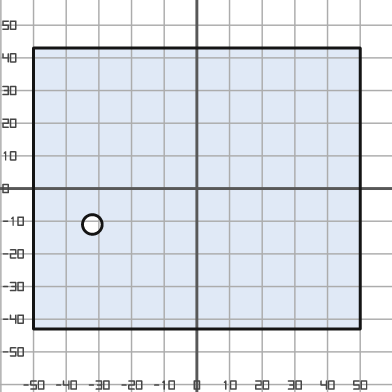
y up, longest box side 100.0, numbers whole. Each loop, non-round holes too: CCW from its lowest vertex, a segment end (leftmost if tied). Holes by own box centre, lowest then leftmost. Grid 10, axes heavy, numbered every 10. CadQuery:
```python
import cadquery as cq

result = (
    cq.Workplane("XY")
    .moveTo(-50.0, -43.0)
    .lineTo(50.0, -43.0)
    .lineTo(50.0, 43.0)
    .lineTo(-50.0, 43.0)
    .close()
    .moveTo(-32.0, -11.0)
    .circle(3.0)
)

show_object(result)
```